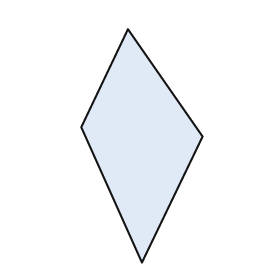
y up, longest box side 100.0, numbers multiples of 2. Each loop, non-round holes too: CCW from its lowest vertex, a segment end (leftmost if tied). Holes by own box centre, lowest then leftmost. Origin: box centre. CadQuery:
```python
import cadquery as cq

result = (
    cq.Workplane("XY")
    .moveTo(0.0, -50.0)
    .lineTo(26.0, 4.0)
    .lineTo(-6.0, 50.0)
    .lineTo(-26.0, 8.0)
    .close()
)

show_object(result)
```